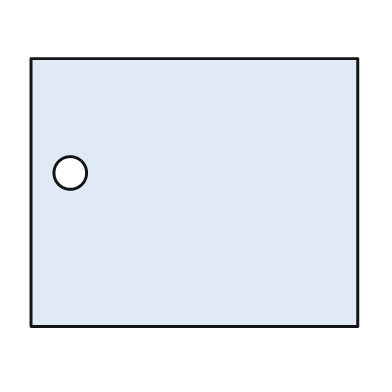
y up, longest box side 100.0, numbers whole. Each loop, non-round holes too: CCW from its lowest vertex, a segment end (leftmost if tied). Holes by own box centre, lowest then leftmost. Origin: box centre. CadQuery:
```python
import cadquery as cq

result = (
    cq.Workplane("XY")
    .moveTo(-50.0, -41.0)
    .lineTo(50.0, -41.0)
    .lineTo(50.0, 41.0)
    .lineTo(-50.0, 41.0)
    .close()
    .moveTo(-38.0, 6.0)
    .circle(5.0)
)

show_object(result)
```